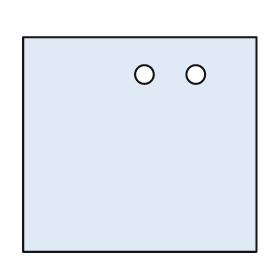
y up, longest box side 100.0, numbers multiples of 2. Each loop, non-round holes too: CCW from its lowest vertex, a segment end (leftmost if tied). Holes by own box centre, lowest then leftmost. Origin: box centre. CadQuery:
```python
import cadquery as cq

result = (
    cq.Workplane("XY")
    .moveTo(-50.0, -46.0)
    .lineTo(50.0, -46.0)
    .lineTo(50.0, 46.0)
    .lineTo(-50.0, 46.0)
    .close()
    .moveTo(2.0, 30.0)
    .circle(4.0)
    .moveTo(24.0, 30.0)
    .circle(4.0)
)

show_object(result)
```